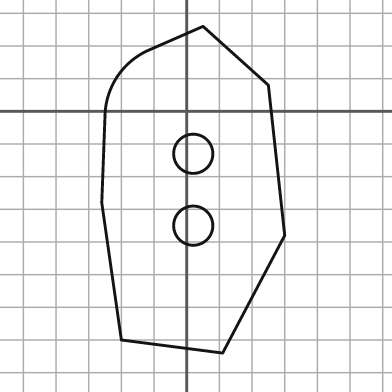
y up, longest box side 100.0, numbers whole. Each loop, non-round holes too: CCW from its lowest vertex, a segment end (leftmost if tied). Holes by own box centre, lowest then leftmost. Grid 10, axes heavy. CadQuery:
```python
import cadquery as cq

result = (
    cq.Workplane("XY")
    .moveTo(11.0, -74.0)
    .lineTo(30.0, -38.0)
    .lineTo(25.0, 8.0)
    .lineTo(5.0, 26.0)
    .lineTo(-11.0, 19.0)
    .threePointArc((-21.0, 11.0), (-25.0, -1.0))
    .lineTo(-26.0, -28.0)
    .lineTo(-20.0, -70.0)
    .close()
    .moveTo(2.0, -35.0)
    .circle(6.0)
    .moveTo(2.0, -13.0)
    .circle(6.0)
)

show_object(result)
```